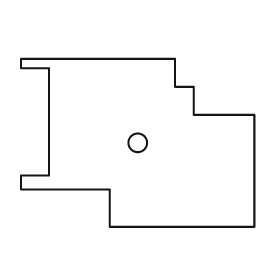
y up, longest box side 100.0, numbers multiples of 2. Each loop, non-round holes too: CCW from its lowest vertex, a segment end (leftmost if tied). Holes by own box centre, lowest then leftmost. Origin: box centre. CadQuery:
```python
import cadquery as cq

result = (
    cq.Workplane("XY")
    .moveTo(-12.0, -36.0)
    .lineTo(50.0, -36.0)
    .lineTo(50.0, 12.0)
    .lineTo(24.0, 12.0)
    .lineTo(24.0, 24.0)
    .lineTo(16.0, 24.0)
    .lineTo(16.0, 36.0)
    .lineTo(-50.0, 36.0)
    .lineTo(-50.0, 32.0)
    .lineTo(-38.0, 32.0)
    .lineTo(-38.0, -14.0)
    .lineTo(-50.0, -14.0)
    .lineTo(-50.0, -20.0)
    .lineTo(-12.0, -20.0)
    .close()
    .moveTo(0.0, 0.0)
    .circle(4.0)
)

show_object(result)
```